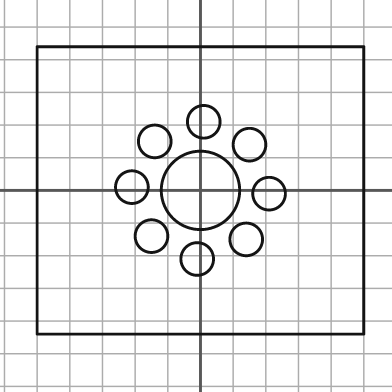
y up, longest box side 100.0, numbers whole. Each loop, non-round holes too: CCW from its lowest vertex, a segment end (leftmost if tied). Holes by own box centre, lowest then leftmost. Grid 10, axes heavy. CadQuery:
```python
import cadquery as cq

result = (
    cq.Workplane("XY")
    .moveTo(-50.0, -44.0)
    .lineTo(50.0, -44.0)
    .lineTo(50.0, 44.0)
    .lineTo(-50.0, 44.0)
    .close()
    .moveTo(-1.0, -21.0)
    .circle(5.0)
    .moveTo(14.0, -15.0)
    .circle(5.0)
    .moveTo(-15.0, -14.0)
    .circle(5.0)
    .moveTo(21.0, -1.0)
    .circle(5.0)
    .moveTo(0.0, 0.0)
    .circle(12.0)
    .moveTo(-21.0, 1.0)
    .circle(5.0)
    .moveTo(15.0, 14.0)
    .circle(5.0)
    .moveTo(-14.0, 15.0)
    .circle(5.0)
    .moveTo(1.0, 21.0)
    .circle(5.0)
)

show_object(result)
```